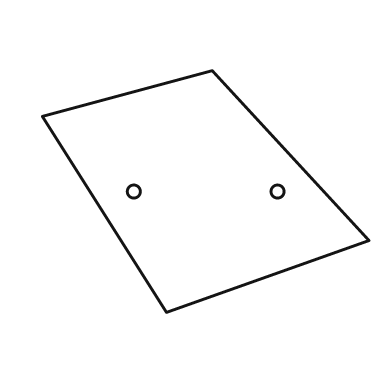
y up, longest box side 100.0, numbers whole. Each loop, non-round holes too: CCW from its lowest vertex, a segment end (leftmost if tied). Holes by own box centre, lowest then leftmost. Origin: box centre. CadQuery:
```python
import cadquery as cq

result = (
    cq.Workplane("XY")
    .moveTo(-12.0, -37.0)
    .lineTo(50.0, -15.0)
    .lineTo(2.0, 37.0)
    .lineTo(-50.0, 23.0)
    .close()
    .moveTo(-22.0, 0.0)
    .circle(2.0)
    .moveTo(22.0, 0.0)
    .circle(2.0)
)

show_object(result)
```